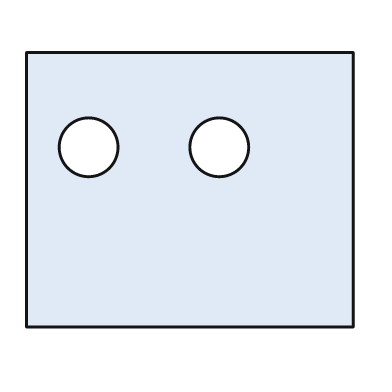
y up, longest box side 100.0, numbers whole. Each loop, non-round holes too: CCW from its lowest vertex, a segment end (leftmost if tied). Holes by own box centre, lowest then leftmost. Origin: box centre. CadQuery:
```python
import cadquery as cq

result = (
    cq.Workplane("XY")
    .moveTo(-50.0, -42.0)
    .lineTo(50.0, -42.0)
    .lineTo(50.0, 42.0)
    .lineTo(-50.0, 42.0)
    .close()
    .moveTo(-31.0, 13.0)
    .circle(9.0)
    .moveTo(9.0, 13.0)
    .circle(9.0)
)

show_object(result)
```